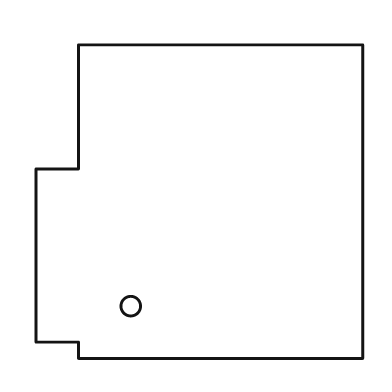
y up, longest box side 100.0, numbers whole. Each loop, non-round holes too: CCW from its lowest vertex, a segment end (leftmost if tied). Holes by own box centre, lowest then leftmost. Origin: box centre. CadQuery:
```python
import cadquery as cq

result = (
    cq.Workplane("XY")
    .moveTo(-37.0, -48.0)
    .lineTo(50.0, -48.0)
    .lineTo(50.0, 48.0)
    .lineTo(-37.0, 48.0)
    .lineTo(-37.0, 10.0)
    .lineTo(-50.0, 10.0)
    .lineTo(-50.0, -43.0)
    .lineTo(-37.0, -43.0)
    .close()
    .moveTo(-21.0, -32.0)
    .circle(3.0)
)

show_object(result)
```